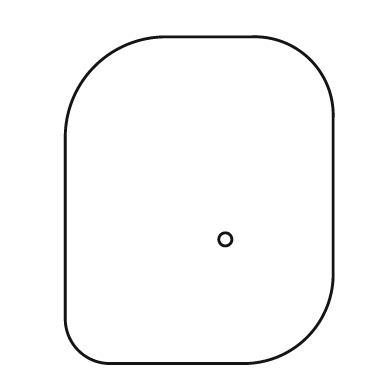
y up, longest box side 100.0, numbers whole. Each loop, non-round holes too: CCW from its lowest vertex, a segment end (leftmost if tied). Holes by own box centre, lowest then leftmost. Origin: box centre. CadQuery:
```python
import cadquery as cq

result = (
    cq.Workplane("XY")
    .moveTo(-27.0, -50.0)
    .lineTo(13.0, -50.0)
    .threePointArc((33.0, -42.0), (41.0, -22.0))
    .lineTo(41.0, 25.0)
    .threePointArc((34.0, 43.0), (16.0, 50.0))
    .lineTo(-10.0, 50.0)
    .threePointArc((-32.0, 41.0), (-41.0, 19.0))
    .lineTo(-41.0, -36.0)
    .threePointArc((-37.0, -46.0), (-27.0, -50.0))
    .close()
    .moveTo(8.0, -12.0)
    .circle(2.0)
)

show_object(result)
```